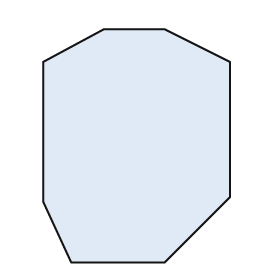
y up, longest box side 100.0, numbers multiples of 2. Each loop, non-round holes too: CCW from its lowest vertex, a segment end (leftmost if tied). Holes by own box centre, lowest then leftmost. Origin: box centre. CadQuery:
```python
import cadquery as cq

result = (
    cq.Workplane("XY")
    .moveTo(-28.0, -50.0)
    .lineTo(12.0, -50.0)
    .lineTo(40.0, -22.0)
    .lineTo(40.0, 36.0)
    .lineTo(12.0, 50.0)
    .lineTo(-14.0, 50.0)
    .lineTo(-40.0, 36.0)
    .lineTo(-40.0, -24.0)
    .close()
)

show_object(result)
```